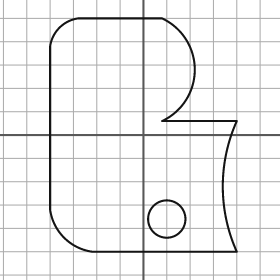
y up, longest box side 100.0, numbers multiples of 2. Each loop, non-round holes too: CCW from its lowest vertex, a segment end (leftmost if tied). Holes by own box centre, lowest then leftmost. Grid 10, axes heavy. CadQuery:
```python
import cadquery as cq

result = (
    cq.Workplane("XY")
    .moveTo(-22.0, -50.0)
    .lineTo(40.0, -50.0)
    .threePointArc((34.0, -22.0), (40.0, 6.0))
    .lineTo(8.0, 6.0)
    .threePointArc((22.0, 28.0), (8.0, 50.0))
    .lineTo(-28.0, 50.0)
    .threePointArc((-36.0, 46.0), (-40.0, 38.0))
    .lineTo(-40.0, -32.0)
    .threePointArc((-34.0, -44.0), (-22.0, -50.0))
    .close()
    .moveTo(10.0, -36.0)
    .circle(8.0)
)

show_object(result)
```